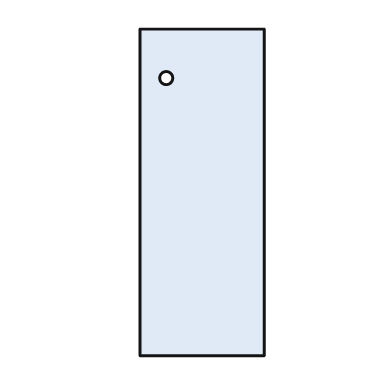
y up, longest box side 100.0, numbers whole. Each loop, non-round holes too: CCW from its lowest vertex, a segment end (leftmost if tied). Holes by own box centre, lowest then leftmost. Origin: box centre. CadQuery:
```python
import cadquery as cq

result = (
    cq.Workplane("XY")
    .moveTo(-19.0, -50.0)
    .lineTo(19.0, -50.0)
    .lineTo(19.0, 50.0)
    .lineTo(-19.0, 50.0)
    .close()
    .moveTo(-11.0, 35.0)
    .circle(2.0)
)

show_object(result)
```